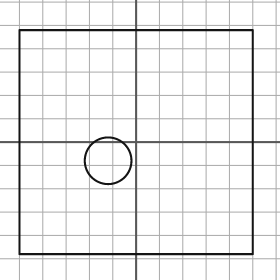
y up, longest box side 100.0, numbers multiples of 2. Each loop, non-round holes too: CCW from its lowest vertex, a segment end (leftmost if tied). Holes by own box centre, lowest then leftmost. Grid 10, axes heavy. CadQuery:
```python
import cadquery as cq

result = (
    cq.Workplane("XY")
    .moveTo(-50.0, -48.0)
    .lineTo(50.0, -48.0)
    .lineTo(50.0, 48.0)
    .lineTo(-50.0, 48.0)
    .close()
    .moveTo(-12.0, -8.0)
    .circle(10.0)
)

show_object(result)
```